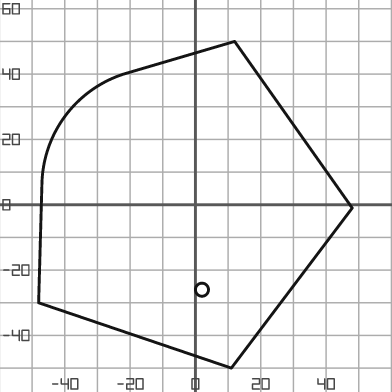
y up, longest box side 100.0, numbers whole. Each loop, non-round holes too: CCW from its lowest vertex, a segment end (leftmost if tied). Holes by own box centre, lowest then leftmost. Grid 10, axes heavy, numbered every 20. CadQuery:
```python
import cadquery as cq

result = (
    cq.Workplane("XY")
    .moveTo(11.0, -50.0)
    .lineTo(48.0, -1.0)
    .lineTo(12.0, 50.0)
    .lineTo(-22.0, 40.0)
    .threePointArc((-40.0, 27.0), (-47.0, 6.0))
    .lineTo(-48.0, -30.0)
    .close()
    .moveTo(2.0, -26.0)
    .circle(2.0)
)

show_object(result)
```